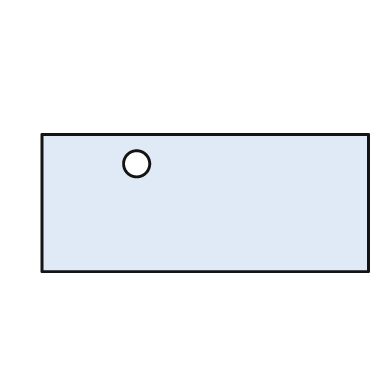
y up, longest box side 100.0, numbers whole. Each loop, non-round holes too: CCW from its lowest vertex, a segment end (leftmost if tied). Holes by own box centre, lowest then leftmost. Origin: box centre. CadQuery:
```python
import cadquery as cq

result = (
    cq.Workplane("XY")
    .moveTo(-50.0, -21.0)
    .lineTo(50.0, -21.0)
    .lineTo(50.0, 21.0)
    .lineTo(-50.0, 21.0)
    .close()
    .moveTo(-21.0, 12.0)
    .circle(4.0)
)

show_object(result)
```